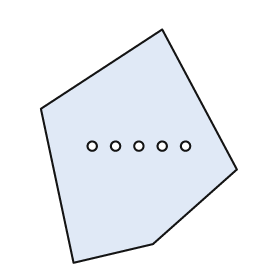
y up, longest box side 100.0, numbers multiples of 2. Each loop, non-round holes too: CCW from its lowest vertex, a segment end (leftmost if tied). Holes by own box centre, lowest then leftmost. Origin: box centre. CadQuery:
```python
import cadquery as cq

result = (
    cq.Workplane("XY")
    .moveTo(-28.0, -50.0)
    .lineTo(6.0, -42.0)
    .lineTo(42.0, -10.0)
    .lineTo(10.0, 50.0)
    .lineTo(-42.0, 16.0)
    .close()
    .moveTo(-20.0, 0.0)
    .circle(2.0)
    .moveTo(-10.0, 0.0)
    .circle(2.0)
    .moveTo(0.0, 0.0)
    .circle(2.0)
    .moveTo(10.0, 0.0)
    .circle(2.0)
    .moveTo(20.0, 0.0)
    .circle(2.0)
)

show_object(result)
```